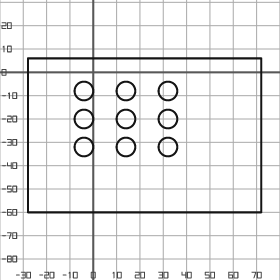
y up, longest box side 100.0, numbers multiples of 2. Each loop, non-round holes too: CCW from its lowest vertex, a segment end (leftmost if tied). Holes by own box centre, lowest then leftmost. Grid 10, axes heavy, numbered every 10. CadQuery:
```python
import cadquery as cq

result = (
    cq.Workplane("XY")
    .moveTo(-28.0, -60.0)
    .lineTo(72.0, -60.0)
    .lineTo(72.0, 6.0)
    .lineTo(-28.0, 6.0)
    .close()
    .moveTo(-4.0, -32.0)
    .circle(4.0)
    .moveTo(14.0, -32.0)
    .circle(4.0)
    .moveTo(32.0, -32.0)
    .circle(4.0)
    .moveTo(-4.0, -20.0)
    .circle(4.0)
    .moveTo(14.0, -20.0)
    .circle(4.0)
    .moveTo(32.0, -20.0)
    .circle(4.0)
    .moveTo(-4.0, -8.0)
    .circle(4.0)
    .moveTo(14.0, -8.0)
    .circle(4.0)
    .moveTo(32.0, -8.0)
    .circle(4.0)
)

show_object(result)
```